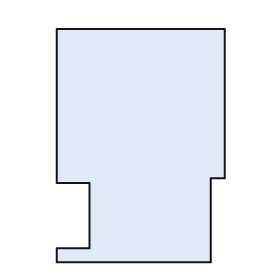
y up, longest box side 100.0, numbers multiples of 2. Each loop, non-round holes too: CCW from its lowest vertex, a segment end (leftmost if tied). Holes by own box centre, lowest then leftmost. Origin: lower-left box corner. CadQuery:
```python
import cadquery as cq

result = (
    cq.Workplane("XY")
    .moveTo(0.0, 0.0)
    .lineTo(66.0, 0.0)
    .lineTo(66.0, 36.0)
    .lineTo(72.0, 36.0)
    .lineTo(72.0, 100.0)
    .lineTo(0.0, 100.0)
    .lineTo(0.0, 34.0)
    .lineTo(14.0, 34.0)
    .lineTo(14.0, 6.0)
    .lineTo(0.0, 6.0)
    .close()
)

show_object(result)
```